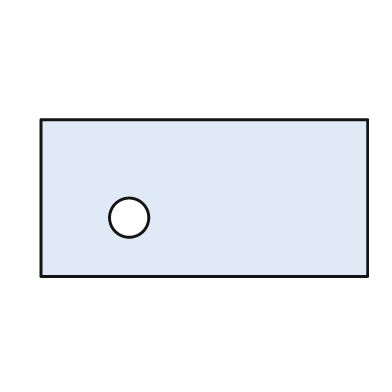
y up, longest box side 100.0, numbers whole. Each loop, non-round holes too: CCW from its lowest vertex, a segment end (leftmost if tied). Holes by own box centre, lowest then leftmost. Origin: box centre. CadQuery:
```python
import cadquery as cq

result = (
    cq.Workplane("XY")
    .moveTo(-50.0, -24.0)
    .lineTo(50.0, -24.0)
    .lineTo(50.0, 24.0)
    .lineTo(-50.0, 24.0)
    .close()
    .moveTo(-23.0, -6.0)
    .circle(6.0)
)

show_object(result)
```